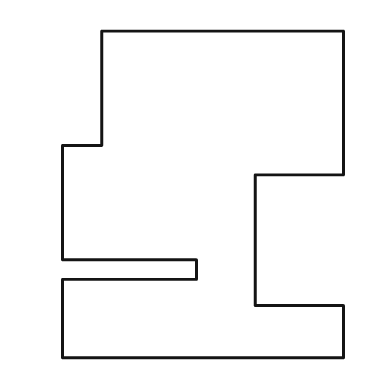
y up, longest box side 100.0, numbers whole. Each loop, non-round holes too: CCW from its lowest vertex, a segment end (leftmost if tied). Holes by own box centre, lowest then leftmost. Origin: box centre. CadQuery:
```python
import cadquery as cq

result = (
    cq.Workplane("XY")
    .moveTo(-43.0, -50.0)
    .lineTo(43.0, -50.0)
    .lineTo(43.0, -34.0)
    .lineTo(16.0, -34.0)
    .lineTo(16.0, 6.0)
    .lineTo(43.0, 6.0)
    .lineTo(43.0, 50.0)
    .lineTo(-31.0, 50.0)
    .lineTo(-31.0, 15.0)
    .lineTo(-43.0, 15.0)
    .lineTo(-43.0, -20.0)
    .lineTo(-2.0, -20.0)
    .lineTo(-2.0, -26.0)
    .lineTo(-43.0, -26.0)
    .close()
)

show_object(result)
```